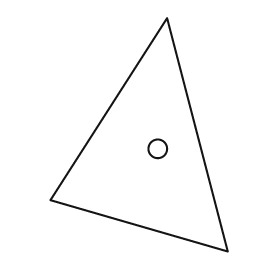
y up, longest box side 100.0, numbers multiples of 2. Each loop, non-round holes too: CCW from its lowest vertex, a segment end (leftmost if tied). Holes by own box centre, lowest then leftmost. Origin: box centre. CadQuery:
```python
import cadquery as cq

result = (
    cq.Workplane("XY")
    .moveTo(38.0, -50.0)
    .lineTo(12.0, 50.0)
    .lineTo(-38.0, -28.0)
    .close()
    .moveTo(8.0, -6.0)
    .circle(4.0)
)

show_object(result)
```